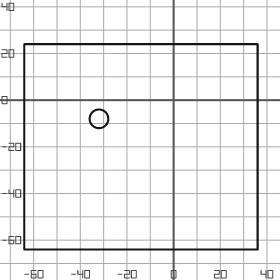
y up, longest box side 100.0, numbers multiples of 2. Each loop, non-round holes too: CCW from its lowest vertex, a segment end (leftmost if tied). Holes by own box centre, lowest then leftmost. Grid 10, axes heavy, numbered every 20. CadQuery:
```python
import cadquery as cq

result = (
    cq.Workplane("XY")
    .moveTo(-64.0, -64.0)
    .lineTo(36.0, -64.0)
    .lineTo(36.0, 24.0)
    .lineTo(-64.0, 24.0)
    .close()
    .moveTo(-32.0, -8.0)
    .circle(4.0)
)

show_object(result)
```